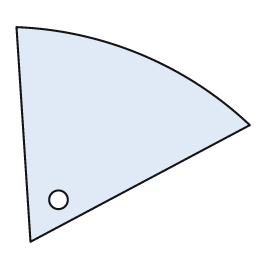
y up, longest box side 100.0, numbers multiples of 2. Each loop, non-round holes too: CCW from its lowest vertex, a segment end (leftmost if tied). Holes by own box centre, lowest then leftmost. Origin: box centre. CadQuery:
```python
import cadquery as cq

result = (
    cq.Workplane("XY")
    .moveTo(-44.0, -46.0)
    .lineTo(50.0, 4.0)
    .threePointArc((4.0, 34.0), (-50.0, 46.0))
    .close()
    .moveTo(-32.0, -28.0)
    .circle(4.0)
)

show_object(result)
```